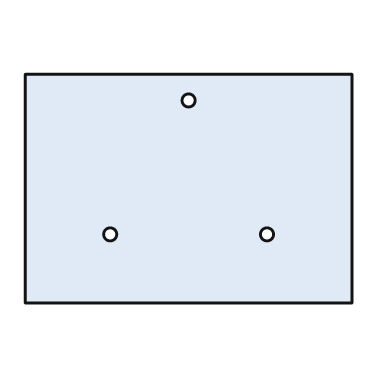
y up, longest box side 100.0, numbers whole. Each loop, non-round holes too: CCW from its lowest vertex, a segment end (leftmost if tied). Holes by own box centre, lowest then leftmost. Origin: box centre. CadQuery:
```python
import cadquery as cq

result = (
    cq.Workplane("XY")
    .moveTo(-50.0, -35.0)
    .lineTo(50.0, -35.0)
    .lineTo(50.0, 35.0)
    .lineTo(-50.0, 35.0)
    .close()
    .moveTo(-24.0, -14.0)
    .circle(2.0)
    .moveTo(24.0, -14.0)
    .circle(2.0)
    .moveTo(0.0, 27.0)
    .circle(2.0)
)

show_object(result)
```